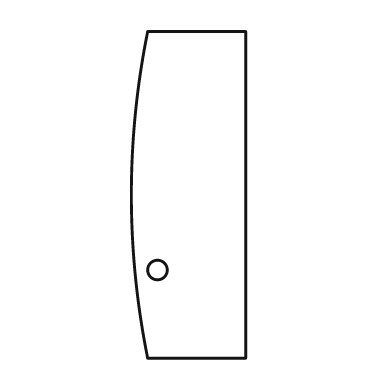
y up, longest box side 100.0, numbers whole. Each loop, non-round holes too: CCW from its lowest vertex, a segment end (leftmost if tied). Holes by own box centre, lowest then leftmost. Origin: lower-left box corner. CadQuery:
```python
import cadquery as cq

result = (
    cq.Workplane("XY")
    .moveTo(5.0, 0.0)
    .lineTo(35.0, 0.0)
    .lineTo(35.0, 100.0)
    .lineTo(5.0, 100.0)
    .threePointArc((0.0, 50.0), (5.0, 0.0))
    .close()
    .moveTo(8.0, 27.0)
    .circle(3.0)
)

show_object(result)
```